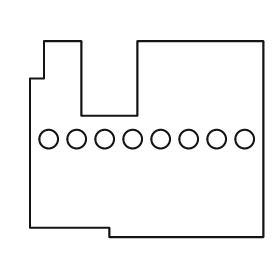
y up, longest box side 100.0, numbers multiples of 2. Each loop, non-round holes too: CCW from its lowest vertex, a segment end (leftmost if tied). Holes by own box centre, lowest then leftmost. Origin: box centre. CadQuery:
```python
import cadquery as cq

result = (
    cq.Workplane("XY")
    .moveTo(-16.0, -42.0)
    .lineTo(50.0, -42.0)
    .lineTo(50.0, 42.0)
    .lineTo(-4.0, 42.0)
    .lineTo(-4.0, 10.0)
    .lineTo(-28.0, 10.0)
    .lineTo(-28.0, 42.0)
    .lineTo(-44.0, 42.0)
    .lineTo(-44.0, 26.0)
    .lineTo(-50.0, 26.0)
    .lineTo(-50.0, -38.0)
    .lineTo(-16.0, -38.0)
    .close()
    .moveTo(-42.0, 0.0)
    .circle(4.0)
    .moveTo(-30.0, 0.0)
    .circle(4.0)
    .moveTo(-18.0, 0.0)
    .circle(4.0)
    .moveTo(-6.0, 0.0)
    .circle(4.0)
    .moveTo(6.0, 0.0)
    .circle(4.0)
    .moveTo(18.0, 0.0)
    .circle(4.0)
    .moveTo(30.0, 0.0)
    .circle(4.0)
    .moveTo(42.0, 0.0)
    .circle(4.0)
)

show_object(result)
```